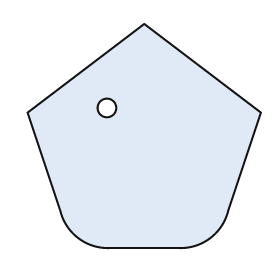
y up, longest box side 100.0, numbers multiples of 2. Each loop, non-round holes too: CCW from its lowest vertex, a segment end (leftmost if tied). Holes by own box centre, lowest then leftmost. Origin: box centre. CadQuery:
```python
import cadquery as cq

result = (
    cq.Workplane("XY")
    .moveTo(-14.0, -48.0)
    .lineTo(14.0, -48.0)
    .threePointArc((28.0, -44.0), (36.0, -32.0))
    .lineTo(50.0, 10.0)
    .lineTo(0.0, 48.0)
    .lineTo(-50.0, 10.0)
    .lineTo(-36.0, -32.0)
    .threePointArc((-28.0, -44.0), (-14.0, -48.0))
    .close()
    .moveTo(-16.0, 12.0)
    .circle(4.0)
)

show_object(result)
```